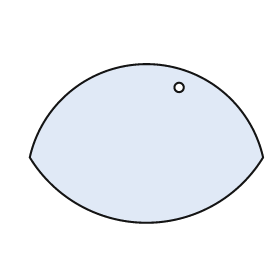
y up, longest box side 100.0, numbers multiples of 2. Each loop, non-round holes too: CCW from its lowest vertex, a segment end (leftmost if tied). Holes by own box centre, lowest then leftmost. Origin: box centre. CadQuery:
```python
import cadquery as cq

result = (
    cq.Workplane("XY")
    .moveTo(-50.0, -6.0)
    .threePointArc((0.0, -34.0), (50.0, -6.0))
    .threePointArc((0.0, 34.0), (-50.0, -6.0))
    .close()
    .moveTo(14.0, 24.0)
    .circle(2.0)
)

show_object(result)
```